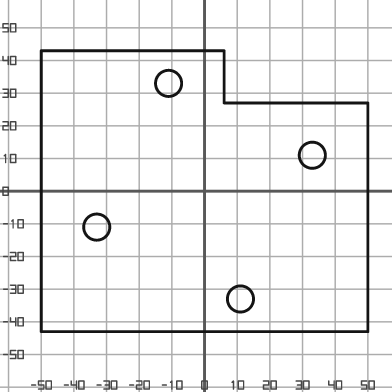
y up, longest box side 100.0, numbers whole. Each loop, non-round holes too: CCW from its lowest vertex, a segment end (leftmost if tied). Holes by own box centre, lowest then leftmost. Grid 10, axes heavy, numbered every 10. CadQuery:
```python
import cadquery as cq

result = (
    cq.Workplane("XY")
    .moveTo(-50.0, -43.0)
    .lineTo(50.0, -43.0)
    .lineTo(50.0, 27.0)
    .lineTo(6.0, 27.0)
    .lineTo(6.0, 43.0)
    .lineTo(-50.0, 43.0)
    .close()
    .moveTo(11.0, -33.0)
    .circle(4.0)
    .moveTo(-33.0, -11.0)
    .circle(4.0)
    .moveTo(33.0, 11.0)
    .circle(4.0)
    .moveTo(-11.0, 33.0)
    .circle(4.0)
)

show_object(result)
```